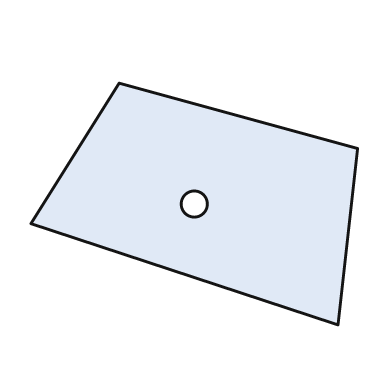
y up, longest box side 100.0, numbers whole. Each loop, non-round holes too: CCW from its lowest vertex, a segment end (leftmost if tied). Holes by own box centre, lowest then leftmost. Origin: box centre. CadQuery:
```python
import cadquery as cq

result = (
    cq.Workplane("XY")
    .moveTo(44.0, -37.0)
    .lineTo(50.0, 17.0)
    .lineTo(-23.0, 37.0)
    .lineTo(-50.0, -6.0)
    .close()
    .moveTo(0.0, 0.0)
    .circle(4.0)
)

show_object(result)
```